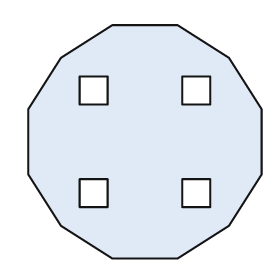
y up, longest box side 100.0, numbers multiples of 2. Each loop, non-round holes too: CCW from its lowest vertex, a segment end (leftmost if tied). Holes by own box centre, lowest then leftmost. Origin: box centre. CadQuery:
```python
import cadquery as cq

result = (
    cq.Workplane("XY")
    .moveTo(-14.0, -50.0)
    .lineTo(14.0, -50.0)
    .lineTo(36.0, -36.0)
    .lineTo(50.0, -14.0)
    .lineTo(50.0, 14.0)
    .lineTo(36.0, 36.0)
    .lineTo(14.0, 50.0)
    .lineTo(-14.0, 50.0)
    .lineTo(-36.0, 36.0)
    .lineTo(-50.0, 14.0)
    .lineTo(-50.0, -14.0)
    .lineTo(-36.0, -36.0)
    .close()
    .moveTo(-28.0, -28.0)
    .lineTo(-16.0, -28.0)
    .lineTo(-16.0, -16.0)
    .lineTo(-28.0, -16.0)
    .close()
    .moveTo(16.0, -28.0)
    .lineTo(28.0, -28.0)
    .lineTo(28.0, -16.0)
    .lineTo(16.0, -16.0)
    .close()
    .moveTo(-28.0, 16.0)
    .lineTo(-16.0, 16.0)
    .lineTo(-16.0, 28.0)
    .lineTo(-28.0, 28.0)
    .close()
    .moveTo(16.0, 16.0)
    .lineTo(28.0, 16.0)
    .lineTo(28.0, 28.0)
    .lineTo(16.0, 28.0)
    .close()
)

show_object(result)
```